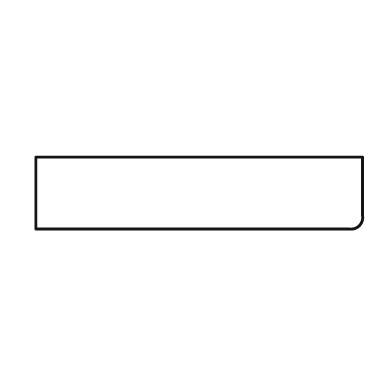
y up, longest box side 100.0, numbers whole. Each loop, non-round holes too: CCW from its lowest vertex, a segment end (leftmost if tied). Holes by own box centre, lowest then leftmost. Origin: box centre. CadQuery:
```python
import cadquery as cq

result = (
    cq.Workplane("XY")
    .moveTo(-50.0, -11.0)
    .lineTo(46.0, -11.0)
    .threePointArc((49.0, -10.0), (50.0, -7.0))
    .lineTo(50.0, 11.0)
    .lineTo(-50.0, 11.0)
    .close()
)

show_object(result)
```